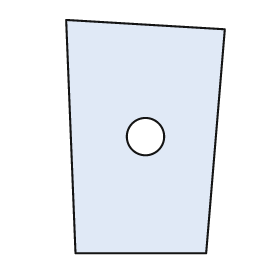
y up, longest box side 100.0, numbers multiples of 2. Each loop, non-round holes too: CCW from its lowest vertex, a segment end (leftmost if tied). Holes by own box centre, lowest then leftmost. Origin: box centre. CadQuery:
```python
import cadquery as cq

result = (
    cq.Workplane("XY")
    .moveTo(-30.0, -50.0)
    .lineTo(26.0, -50.0)
    .lineTo(34.0, 46.0)
    .lineTo(-34.0, 50.0)
    .close()
    .moveTo(0.0, 0.0)
    .circle(8.0)
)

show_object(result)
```